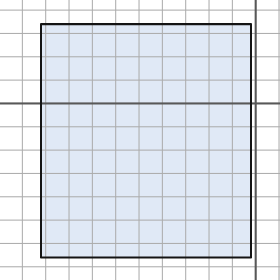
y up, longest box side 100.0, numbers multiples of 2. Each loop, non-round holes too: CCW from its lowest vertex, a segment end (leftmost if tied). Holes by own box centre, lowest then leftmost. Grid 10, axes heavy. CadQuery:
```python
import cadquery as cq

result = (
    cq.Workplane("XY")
    .moveTo(-92.0, -66.0)
    .lineTo(-2.0, -66.0)
    .lineTo(-2.0, 34.0)
    .lineTo(-92.0, 34.0)
    .close()
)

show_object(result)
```